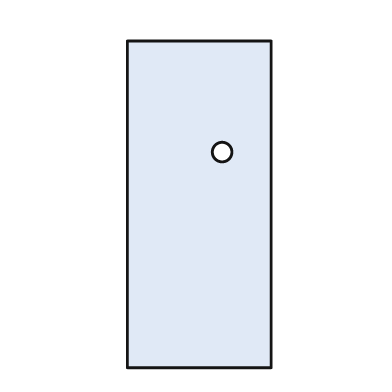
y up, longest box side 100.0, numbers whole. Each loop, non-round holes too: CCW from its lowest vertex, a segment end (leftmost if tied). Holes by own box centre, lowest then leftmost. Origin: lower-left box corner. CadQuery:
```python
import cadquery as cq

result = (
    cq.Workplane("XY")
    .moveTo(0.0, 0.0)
    .lineTo(44.0, 0.0)
    .lineTo(44.0, 100.0)
    .lineTo(0.0, 100.0)
    .close()
    .moveTo(29.0, 66.0)
    .circle(3.0)
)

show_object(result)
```